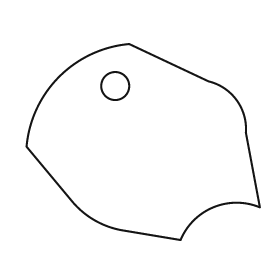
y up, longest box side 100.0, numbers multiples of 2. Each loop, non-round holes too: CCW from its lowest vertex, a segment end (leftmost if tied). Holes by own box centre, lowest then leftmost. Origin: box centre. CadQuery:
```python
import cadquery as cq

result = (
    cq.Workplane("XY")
    .moveTo(16.0, -42.0)
    .threePointArc((30.0, -28.0), (50.0, -28.0))
    .lineTo(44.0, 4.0)
    .threePointArc((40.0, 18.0), (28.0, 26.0))
    .lineTo(-6.0, 42.0)
    .threePointArc((-36.0, 28.0), (-50.0, -2.0))
    .lineTo(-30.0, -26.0)
    .threePointArc((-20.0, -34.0), (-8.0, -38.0))
    .close()
    .moveTo(-12.0, 24.0)
    .circle(6.0)
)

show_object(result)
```